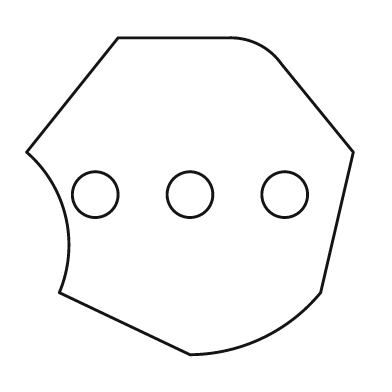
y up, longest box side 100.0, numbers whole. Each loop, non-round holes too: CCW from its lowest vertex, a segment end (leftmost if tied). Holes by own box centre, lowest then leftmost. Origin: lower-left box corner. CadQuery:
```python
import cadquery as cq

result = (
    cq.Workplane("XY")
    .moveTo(50.0, 0.0)
    .threePointArc((72.0, 5.0), (90.0, 19.0))
    .lineTo(100.0, 62.0)
    .lineTo(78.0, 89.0)
    .threePointArc((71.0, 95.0), (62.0, 97.0))
    .lineTo(28.0, 97.0)
    .lineTo(0.0, 62.0)
    .threePointArc((12.0, 42.0), (10.0, 19.0))
    .close()
    .moveTo(21.0, 49.0)
    .circle(7.0)
    .moveTo(50.0, 49.0)
    .circle(7.0)
    .moveTo(79.0, 49.0)
    .circle(7.0)
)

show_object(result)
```